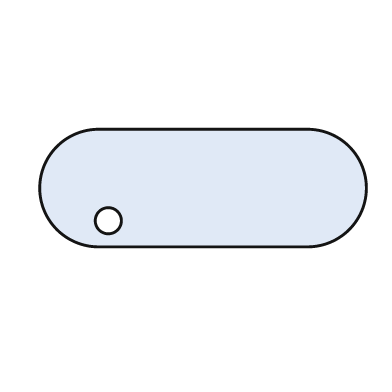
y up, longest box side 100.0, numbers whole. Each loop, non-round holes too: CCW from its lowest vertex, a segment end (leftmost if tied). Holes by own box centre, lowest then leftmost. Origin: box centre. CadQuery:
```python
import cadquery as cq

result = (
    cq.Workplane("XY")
    .moveTo(-32.0, -18.0)
    .lineTo(32.0, -18.0)
    .threePointArc((50.0, 0.0), (32.0, 18.0))
    .lineTo(-32.0, 18.0)
    .threePointArc((-50.0, 0.0), (-32.0, -18.0))
    .close()
    .moveTo(-29.0, -10.0)
    .circle(4.0)
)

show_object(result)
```